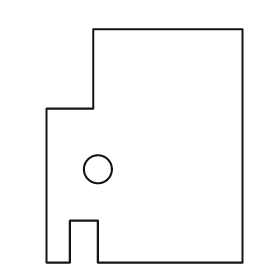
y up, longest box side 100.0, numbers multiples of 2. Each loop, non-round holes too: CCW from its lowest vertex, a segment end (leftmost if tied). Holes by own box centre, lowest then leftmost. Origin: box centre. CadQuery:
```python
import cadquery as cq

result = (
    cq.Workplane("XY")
    .moveTo(-42.0, -50.0)
    .lineTo(-32.0, -50.0)
    .lineTo(-32.0, -32.0)
    .lineTo(-20.0, -32.0)
    .lineTo(-20.0, -50.0)
    .lineTo(42.0, -50.0)
    .lineTo(42.0, 50.0)
    .lineTo(-22.0, 50.0)
    .lineTo(-22.0, 16.0)
    .lineTo(-42.0, 16.0)
    .close()
    .moveTo(-20.0, -10.0)
    .circle(6.0)
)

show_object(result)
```